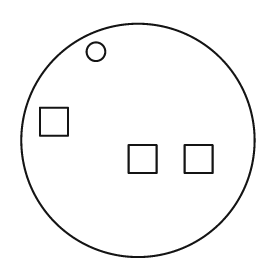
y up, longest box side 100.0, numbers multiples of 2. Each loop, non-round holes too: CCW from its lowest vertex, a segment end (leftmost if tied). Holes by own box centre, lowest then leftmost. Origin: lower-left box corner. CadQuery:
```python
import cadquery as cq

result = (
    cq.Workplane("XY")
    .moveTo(50.0, 50.0)
    .circle(50.0)
    .moveTo(46.0, 36.0)
    .lineTo(58.0, 36.0)
    .lineTo(58.0, 48.0)
    .lineTo(46.0, 48.0)
    .close()
    .moveTo(70.0, 36.0)
    .lineTo(82.0, 36.0)
    .lineTo(82.0, 48.0)
    .lineTo(70.0, 48.0)
    .close()
    .moveTo(8.0, 52.0)
    .lineTo(20.0, 52.0)
    .lineTo(20.0, 64.0)
    .lineTo(8.0, 64.0)
    .close()
    .moveTo(32.0, 88.0)
    .circle(4.0)
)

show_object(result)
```